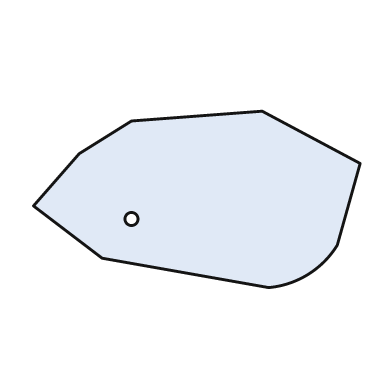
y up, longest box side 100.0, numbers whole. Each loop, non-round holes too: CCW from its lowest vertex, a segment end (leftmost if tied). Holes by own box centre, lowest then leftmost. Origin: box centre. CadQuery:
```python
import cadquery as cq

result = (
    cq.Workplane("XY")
    .moveTo(22.0, -27.0)
    .threePointArc((34.0, -23.0), (43.0, -14.0))
    .lineTo(50.0, 11.0)
    .lineTo(20.0, 27.0)
    .lineTo(-20.0, 24.0)
    .lineTo(-36.0, 14.0)
    .lineTo(-50.0, -2.0)
    .lineTo(-29.0, -18.0)
    .close()
    .moveTo(-20.0, -6.0)
    .circle(2.0)
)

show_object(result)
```